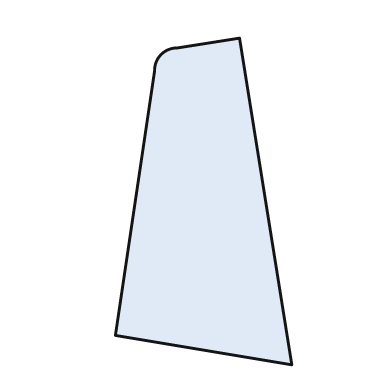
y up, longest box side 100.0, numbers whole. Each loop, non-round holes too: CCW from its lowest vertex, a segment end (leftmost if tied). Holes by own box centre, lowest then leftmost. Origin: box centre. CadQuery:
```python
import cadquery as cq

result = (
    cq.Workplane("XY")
    .moveTo(27.0, -50.0)
    .lineTo(11.0, 50.0)
    .lineTo(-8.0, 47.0)
    .threePointArc((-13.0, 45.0), (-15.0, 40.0))
    .lineTo(-27.0, -41.0)
    .close()
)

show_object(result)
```